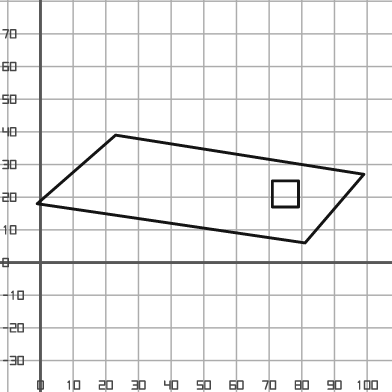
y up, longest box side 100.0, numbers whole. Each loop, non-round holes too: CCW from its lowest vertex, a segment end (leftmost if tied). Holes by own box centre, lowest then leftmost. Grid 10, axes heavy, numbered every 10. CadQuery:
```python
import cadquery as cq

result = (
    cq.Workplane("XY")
    .moveTo(81.0, 6.0)
    .lineTo(99.0, 27.0)
    .lineTo(23.0, 39.0)
    .lineTo(-1.0, 18.0)
    .close()
    .moveTo(71.0, 17.0)
    .lineTo(79.0, 17.0)
    .lineTo(79.0, 25.0)
    .lineTo(71.0, 25.0)
    .close()
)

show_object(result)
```